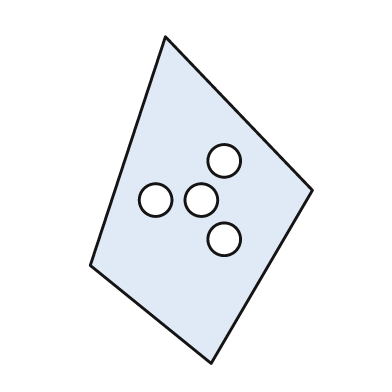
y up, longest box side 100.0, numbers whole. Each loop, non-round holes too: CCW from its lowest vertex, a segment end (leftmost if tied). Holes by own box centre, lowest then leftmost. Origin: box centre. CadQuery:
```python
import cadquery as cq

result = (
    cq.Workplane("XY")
    .moveTo(3.0, -50.0)
    .lineTo(34.0, 3.0)
    .lineTo(-11.0, 50.0)
    .lineTo(-34.0, -20.0)
    .close()
    .moveTo(7.0, -12.0)
    .circle(5.0)
    .moveTo(-14.0, 0.0)
    .circle(5.0)
    .moveTo(0.0, 0.0)
    .circle(5.0)
    .moveTo(7.0, 12.0)
    .circle(5.0)
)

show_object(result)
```